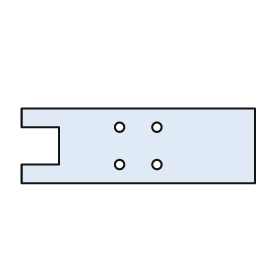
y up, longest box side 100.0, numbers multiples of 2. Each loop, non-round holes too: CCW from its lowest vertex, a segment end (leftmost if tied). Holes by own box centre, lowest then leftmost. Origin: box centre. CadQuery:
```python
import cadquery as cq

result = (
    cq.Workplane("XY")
    .moveTo(-50.0, -16.0)
    .lineTo(50.0, -16.0)
    .lineTo(50.0, 16.0)
    .lineTo(-50.0, 16.0)
    .lineTo(-50.0, 8.0)
    .lineTo(-34.0, 8.0)
    .lineTo(-34.0, -8.0)
    .lineTo(-50.0, -8.0)
    .close()
    .moveTo(-8.0, -8.0)
    .circle(2.0)
    .moveTo(8.0, -8.0)
    .circle(2.0)
    .moveTo(-8.0, 8.0)
    .circle(2.0)
    .moveTo(8.0, 8.0)
    .circle(2.0)
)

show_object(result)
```